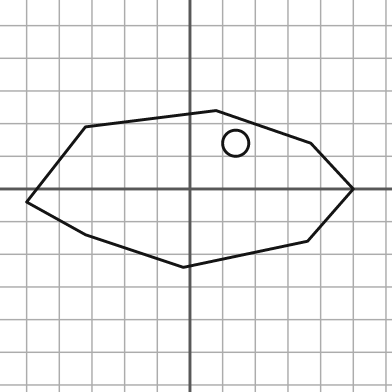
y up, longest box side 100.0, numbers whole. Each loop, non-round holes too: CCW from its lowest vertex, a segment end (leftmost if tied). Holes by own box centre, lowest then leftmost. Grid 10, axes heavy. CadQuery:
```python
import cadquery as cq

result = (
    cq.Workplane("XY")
    .moveTo(-2.0, -24.0)
    .lineTo(36.0, -16.0)
    .lineTo(50.0, 0.0)
    .lineTo(37.0, 14.0)
    .lineTo(8.0, 24.0)
    .lineTo(-32.0, 19.0)
    .lineTo(-50.0, -4.0)
    .lineTo(-32.0, -14.0)
    .close()
    .moveTo(14.0, 14.0)
    .circle(4.0)
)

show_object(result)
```